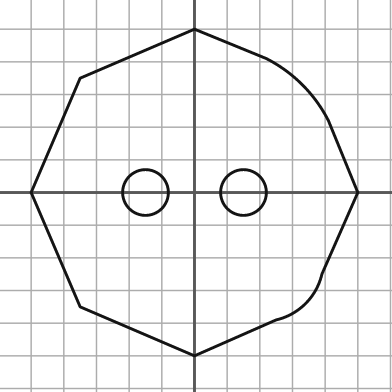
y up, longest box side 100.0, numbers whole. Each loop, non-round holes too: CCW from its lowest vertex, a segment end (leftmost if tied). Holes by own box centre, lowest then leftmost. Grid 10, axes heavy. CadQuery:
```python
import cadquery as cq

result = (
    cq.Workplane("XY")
    .moveTo(0.0, -50.0)
    .lineTo(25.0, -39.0)
    .threePointArc((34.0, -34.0), (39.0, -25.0))
    .lineTo(50.0, 0.0)
    .lineTo(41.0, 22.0)
    .threePointArc((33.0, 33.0), (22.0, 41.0))
    .lineTo(0.0, 50.0)
    .lineTo(-35.0, 35.0)
    .lineTo(-50.0, 0.0)
    .lineTo(-35.0, -35.0)
    .close()
    .moveTo(-15.0, 0.0)
    .circle(7.0)
    .moveTo(15.0, 0.0)
    .circle(7.0)
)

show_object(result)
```